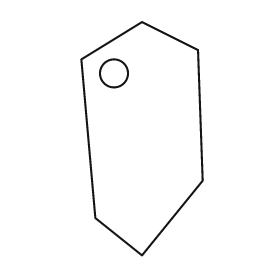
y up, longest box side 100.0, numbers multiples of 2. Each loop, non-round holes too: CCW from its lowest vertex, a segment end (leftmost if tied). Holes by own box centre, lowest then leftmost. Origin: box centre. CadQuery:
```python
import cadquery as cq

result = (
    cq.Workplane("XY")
    .moveTo(0.0, -50.0)
    .lineTo(26.0, -18.0)
    .lineTo(24.0, 38.0)
    .lineTo(0.0, 50.0)
    .lineTo(-26.0, 34.0)
    .lineTo(-20.0, -34.0)
    .close()
    .moveTo(-12.0, 28.0)
    .circle(6.0)
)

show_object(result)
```